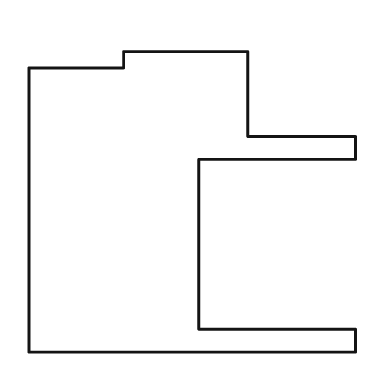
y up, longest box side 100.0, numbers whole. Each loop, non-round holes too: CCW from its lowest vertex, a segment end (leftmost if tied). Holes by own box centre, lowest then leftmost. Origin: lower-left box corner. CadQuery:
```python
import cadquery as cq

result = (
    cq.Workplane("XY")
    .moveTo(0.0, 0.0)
    .lineTo(100.0, 0.0)
    .lineTo(100.0, 7.0)
    .lineTo(52.0, 7.0)
    .lineTo(52.0, 59.0)
    .lineTo(100.0, 59.0)
    .lineTo(100.0, 66.0)
    .lineTo(67.0, 66.0)
    .lineTo(67.0, 92.0)
    .lineTo(29.0, 92.0)
    .lineTo(29.0, 87.0)
    .lineTo(0.0, 87.0)
    .close()
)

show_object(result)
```